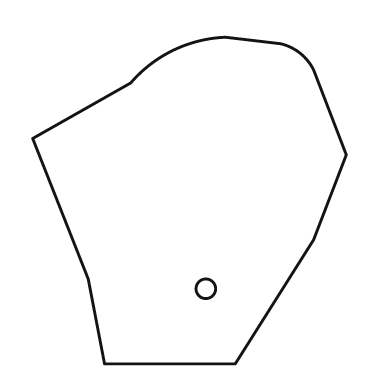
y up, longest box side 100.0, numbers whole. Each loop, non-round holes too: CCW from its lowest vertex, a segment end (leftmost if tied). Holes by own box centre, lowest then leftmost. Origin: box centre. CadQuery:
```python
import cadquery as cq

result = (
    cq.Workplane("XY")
    .moveTo(-26.0, -50.0)
    .lineTo(14.0, -50.0)
    .lineTo(38.0, -12.0)
    .lineTo(48.0, 14.0)
    .lineTo(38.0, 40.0)
    .threePointArc((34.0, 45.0), (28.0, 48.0))
    .lineTo(11.0, 50.0)
    .threePointArc((-5.0, 46.0), (-18.0, 36.0))
    .lineTo(-48.0, 19.0)
    .lineTo(-31.0, -24.0)
    .close()
    .moveTo(5.0, -27.0)
    .circle(3.0)
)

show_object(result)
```